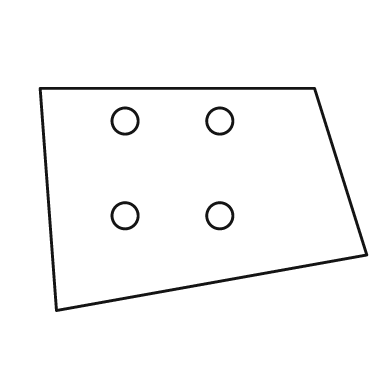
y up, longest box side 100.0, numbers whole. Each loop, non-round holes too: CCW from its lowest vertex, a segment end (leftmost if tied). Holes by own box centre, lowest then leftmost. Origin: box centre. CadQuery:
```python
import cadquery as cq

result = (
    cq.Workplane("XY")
    .moveTo(-45.0, -34.0)
    .lineTo(50.0, -17.0)
    .lineTo(34.0, 34.0)
    .lineTo(-50.0, 34.0)
    .close()
    .moveTo(-24.0, -5.0)
    .circle(4.0)
    .moveTo(5.0, -5.0)
    .circle(4.0)
    .moveTo(-24.0, 24.0)
    .circle(4.0)
    .moveTo(5.0, 24.0)
    .circle(4.0)
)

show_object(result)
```